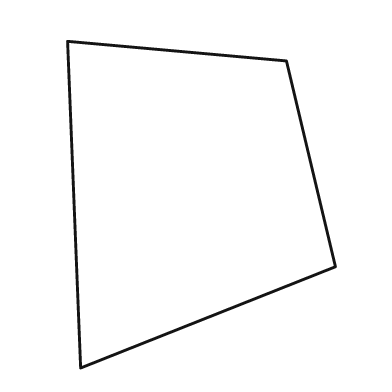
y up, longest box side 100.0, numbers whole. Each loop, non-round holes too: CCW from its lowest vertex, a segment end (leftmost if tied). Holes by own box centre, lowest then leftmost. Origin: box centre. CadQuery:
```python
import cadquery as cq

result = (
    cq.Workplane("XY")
    .moveTo(-37.0, -50.0)
    .lineTo(41.0, -19.0)
    .lineTo(26.0, 44.0)
    .lineTo(-41.0, 50.0)
    .close()
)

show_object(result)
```